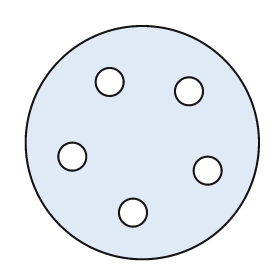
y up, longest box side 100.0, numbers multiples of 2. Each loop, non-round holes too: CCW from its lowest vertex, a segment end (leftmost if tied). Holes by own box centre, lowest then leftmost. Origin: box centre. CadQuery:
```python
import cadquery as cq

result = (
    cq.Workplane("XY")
    .moveTo(0.0, 0.0)
    .circle(50.0)
    .moveTo(-4.0, -30.0)
    .circle(6.0)
    .moveTo(28.0, -12.0)
    .circle(6.0)
    .moveTo(-30.0, -6.0)
    .circle(6.0)
    .moveTo(20.0, 22.0)
    .circle(6.0)
    .moveTo(-14.0, 26.0)
    .circle(6.0)
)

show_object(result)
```